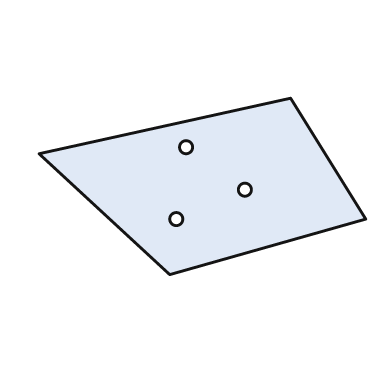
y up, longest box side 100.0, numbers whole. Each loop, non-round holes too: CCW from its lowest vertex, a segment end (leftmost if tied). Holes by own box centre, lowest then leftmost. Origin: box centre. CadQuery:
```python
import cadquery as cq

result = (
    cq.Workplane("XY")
    .moveTo(-10.0, -27.0)
    .lineTo(50.0, -10.0)
    .lineTo(27.0, 27.0)
    .lineTo(-50.0, 10.0)
    .close()
    .moveTo(-8.0, -10.0)
    .circle(2.0)
    .moveTo(13.0, -1.0)
    .circle(2.0)
    .moveTo(-5.0, 12.0)
    .circle(2.0)
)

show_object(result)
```